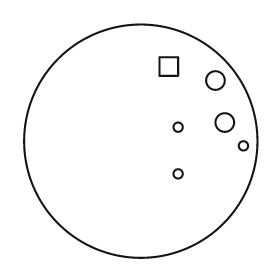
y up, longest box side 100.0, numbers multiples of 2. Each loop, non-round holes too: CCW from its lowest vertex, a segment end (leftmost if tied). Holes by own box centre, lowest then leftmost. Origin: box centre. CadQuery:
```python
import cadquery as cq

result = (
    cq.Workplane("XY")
    .moveTo(0.0, 0.0)
    .circle(50.0)
    .moveTo(16.0, -14.0)
    .circle(2.0)
    .moveTo(44.0, -2.0)
    .circle(2.0)
    .moveTo(16.0, 6.0)
    .circle(2.0)
    .moveTo(36.0, 8.0)
    .circle(4.0)
    .moveTo(32.0, 26.0)
    .circle(4.0)
    .moveTo(8.0, 28.0)
    .lineTo(16.0, 28.0)
    .lineTo(16.0, 36.0)
    .lineTo(8.0, 36.0)
    .close()
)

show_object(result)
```